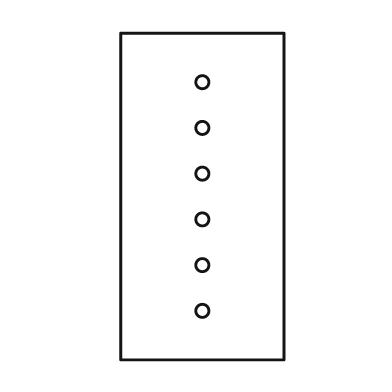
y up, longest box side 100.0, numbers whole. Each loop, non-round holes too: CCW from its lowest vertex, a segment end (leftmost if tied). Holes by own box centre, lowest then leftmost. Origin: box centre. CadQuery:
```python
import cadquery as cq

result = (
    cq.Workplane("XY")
    .moveTo(-25.0, -50.0)
    .lineTo(25.0, -50.0)
    .lineTo(25.0, 50.0)
    .lineTo(-25.0, 50.0)
    .close()
    .moveTo(0.0, -35.0)
    .circle(2.0)
    .moveTo(0.0, -21.0)
    .circle(2.0)
    .moveTo(0.0, -7.0)
    .circle(2.0)
    .moveTo(0.0, 7.0)
    .circle(2.0)
    .moveTo(0.0, 21.0)
    .circle(2.0)
    .moveTo(0.0, 35.0)
    .circle(2.0)
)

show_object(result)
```